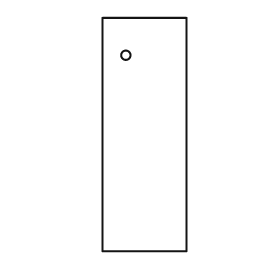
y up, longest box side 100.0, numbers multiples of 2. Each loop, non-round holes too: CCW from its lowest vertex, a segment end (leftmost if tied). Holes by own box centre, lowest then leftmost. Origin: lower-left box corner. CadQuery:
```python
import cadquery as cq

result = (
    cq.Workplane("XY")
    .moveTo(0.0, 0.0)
    .lineTo(36.0, 0.0)
    .lineTo(36.0, 100.0)
    .lineTo(0.0, 100.0)
    .close()
    .moveTo(10.0, 84.0)
    .circle(2.0)
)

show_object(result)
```